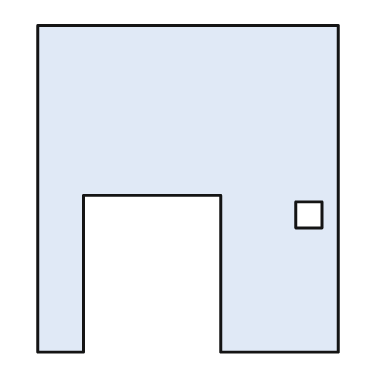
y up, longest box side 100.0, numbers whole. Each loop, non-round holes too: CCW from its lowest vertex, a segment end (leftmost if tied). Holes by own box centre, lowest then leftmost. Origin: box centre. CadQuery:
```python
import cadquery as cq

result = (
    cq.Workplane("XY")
    .moveTo(-46.0, -50.0)
    .lineTo(-32.0, -50.0)
    .lineTo(-32.0, -2.0)
    .lineTo(10.0, -2.0)
    .lineTo(10.0, -50.0)
    .lineTo(46.0, -50.0)
    .lineTo(46.0, 50.0)
    .lineTo(-46.0, 50.0)
    .close()
    .moveTo(33.0, -12.0)
    .lineTo(41.0, -12.0)
    .lineTo(41.0, -4.0)
    .lineTo(33.0, -4.0)
    .close()
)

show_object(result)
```